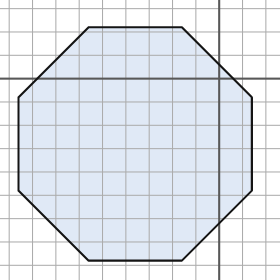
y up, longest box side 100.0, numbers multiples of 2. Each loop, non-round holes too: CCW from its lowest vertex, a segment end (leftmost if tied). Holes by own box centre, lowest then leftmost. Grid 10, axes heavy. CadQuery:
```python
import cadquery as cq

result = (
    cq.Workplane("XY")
    .moveTo(-56.0, -78.0)
    .lineTo(-16.0, -78.0)
    .lineTo(14.0, -48.0)
    .lineTo(14.0, -8.0)
    .lineTo(-16.0, 22.0)
    .lineTo(-56.0, 22.0)
    .lineTo(-86.0, -8.0)
    .lineTo(-86.0, -48.0)
    .close()
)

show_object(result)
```